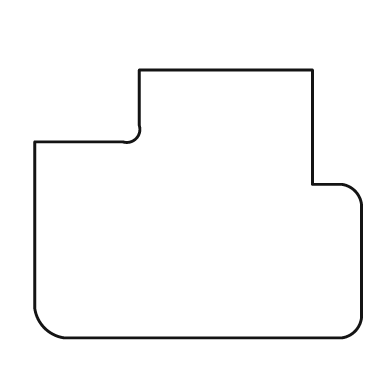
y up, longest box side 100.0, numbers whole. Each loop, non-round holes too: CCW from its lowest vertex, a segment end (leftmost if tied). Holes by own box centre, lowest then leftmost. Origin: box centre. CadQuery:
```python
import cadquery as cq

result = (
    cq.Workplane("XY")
    .moveTo(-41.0, -41.0)
    .lineTo(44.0, -41.0)
    .threePointArc((48.0, -39.0), (50.0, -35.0))
    .lineTo(50.0, 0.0)
    .threePointArc((48.0, 4.0), (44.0, 6.0))
    .lineTo(35.0, 6.0)
    .lineTo(35.0, 41.0)
    .lineTo(-18.0, 41.0)
    .lineTo(-18.0, 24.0)
    .threePointArc((-19.0, 20.0), (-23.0, 19.0))
    .lineTo(-50.0, 19.0)
    .lineTo(-50.0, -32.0)
    .threePointArc((-47.0, -38.0), (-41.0, -41.0))
    .close()
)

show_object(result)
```